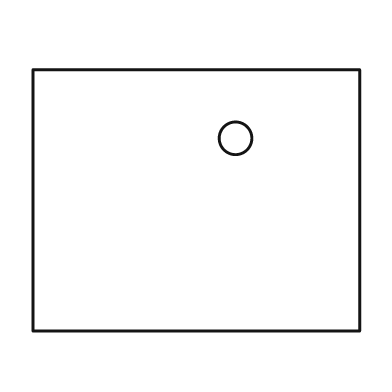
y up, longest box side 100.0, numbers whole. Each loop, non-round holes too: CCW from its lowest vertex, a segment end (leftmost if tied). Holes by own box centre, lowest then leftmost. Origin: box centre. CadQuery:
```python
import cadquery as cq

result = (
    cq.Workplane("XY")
    .moveTo(-50.0, -40.0)
    .lineTo(50.0, -40.0)
    .lineTo(50.0, 40.0)
    .lineTo(-50.0, 40.0)
    .close()
    .moveTo(12.0, 19.0)
    .circle(5.0)
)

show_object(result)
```